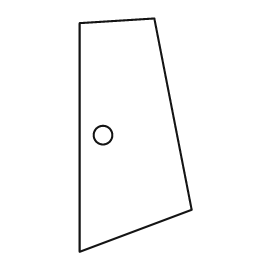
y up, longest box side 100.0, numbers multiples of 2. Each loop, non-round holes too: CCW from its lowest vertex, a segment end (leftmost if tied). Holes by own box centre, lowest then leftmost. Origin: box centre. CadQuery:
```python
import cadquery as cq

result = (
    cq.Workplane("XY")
    .moveTo(-24.0, -50.0)
    .lineTo(24.0, -32.0)
    .lineTo(8.0, 50.0)
    .lineTo(-24.0, 48.0)
    .close()
    .moveTo(-14.0, 0.0)
    .circle(4.0)
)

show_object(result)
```